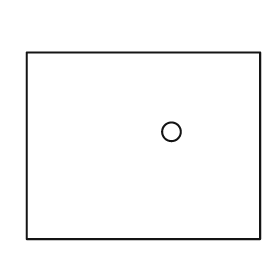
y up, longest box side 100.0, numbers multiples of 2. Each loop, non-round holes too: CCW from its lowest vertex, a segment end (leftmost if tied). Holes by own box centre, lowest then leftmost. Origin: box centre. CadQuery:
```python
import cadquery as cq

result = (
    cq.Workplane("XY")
    .moveTo(-50.0, -40.0)
    .lineTo(50.0, -40.0)
    .lineTo(50.0, 40.0)
    .lineTo(-50.0, 40.0)
    .close()
    .moveTo(12.0, 6.0)
    .circle(4.0)
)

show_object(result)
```